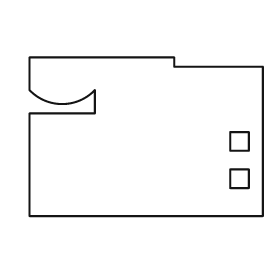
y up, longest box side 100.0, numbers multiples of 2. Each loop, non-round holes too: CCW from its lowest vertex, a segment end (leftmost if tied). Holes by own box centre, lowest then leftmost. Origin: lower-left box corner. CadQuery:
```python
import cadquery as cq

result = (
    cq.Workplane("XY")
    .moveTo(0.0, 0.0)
    .lineTo(100.0, 0.0)
    .lineTo(100.0, 64.0)
    .lineTo(62.0, 64.0)
    .lineTo(62.0, 68.0)
    .lineTo(0.0, 68.0)
    .lineTo(0.0, 54.0)
    .threePointArc((14.0, 48.0), (28.0, 54.0))
    .lineTo(28.0, 44.0)
    .lineTo(0.0, 44.0)
    .close()
    .moveTo(86.0, 12.0)
    .lineTo(94.0, 12.0)
    .lineTo(94.0, 20.0)
    .lineTo(86.0, 20.0)
    .close()
    .moveTo(86.0, 28.0)
    .lineTo(94.0, 28.0)
    .lineTo(94.0, 36.0)
    .lineTo(86.0, 36.0)
    .close()
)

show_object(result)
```